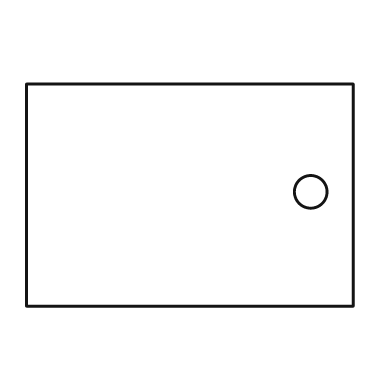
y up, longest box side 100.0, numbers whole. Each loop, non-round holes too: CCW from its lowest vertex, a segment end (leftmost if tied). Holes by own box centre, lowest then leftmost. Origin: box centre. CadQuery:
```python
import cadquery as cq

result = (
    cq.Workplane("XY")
    .moveTo(-50.0, -34.0)
    .lineTo(50.0, -34.0)
    .lineTo(50.0, 34.0)
    .lineTo(-50.0, 34.0)
    .close()
    .moveTo(37.0, 1.0)
    .circle(5.0)
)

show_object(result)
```